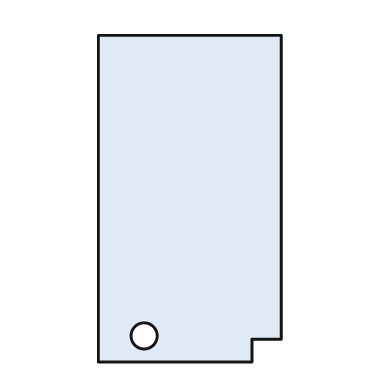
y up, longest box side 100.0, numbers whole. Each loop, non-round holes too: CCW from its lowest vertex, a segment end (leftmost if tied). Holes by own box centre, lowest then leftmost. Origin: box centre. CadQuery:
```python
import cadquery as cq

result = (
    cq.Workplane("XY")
    .moveTo(-28.0, -50.0)
    .lineTo(19.0, -50.0)
    .lineTo(19.0, -43.0)
    .lineTo(28.0, -43.0)
    .lineTo(28.0, 50.0)
    .lineTo(-28.0, 50.0)
    .close()
    .moveTo(-14.0, -42.0)
    .circle(4.0)
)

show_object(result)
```